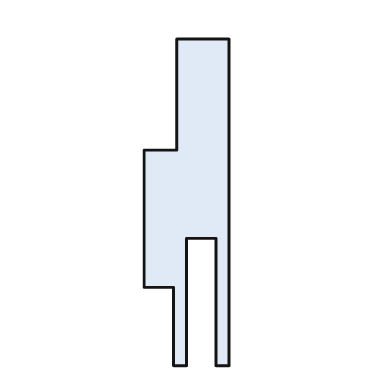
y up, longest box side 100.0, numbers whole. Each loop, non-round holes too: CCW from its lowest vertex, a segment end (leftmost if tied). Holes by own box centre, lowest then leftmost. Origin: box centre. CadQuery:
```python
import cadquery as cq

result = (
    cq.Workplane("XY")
    .moveTo(-4.0, -50.0)
    .lineTo(0.0, -50.0)
    .lineTo(0.0, -11.0)
    .lineTo(9.0, -11.0)
    .lineTo(9.0, -50.0)
    .lineTo(13.0, -50.0)
    .lineTo(13.0, 50.0)
    .lineTo(-3.0, 50.0)
    .lineTo(-3.0, 16.0)
    .lineTo(-13.0, 16.0)
    .lineTo(-13.0, -26.0)
    .lineTo(-4.0, -26.0)
    .close()
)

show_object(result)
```